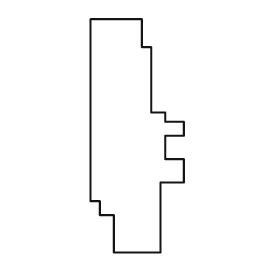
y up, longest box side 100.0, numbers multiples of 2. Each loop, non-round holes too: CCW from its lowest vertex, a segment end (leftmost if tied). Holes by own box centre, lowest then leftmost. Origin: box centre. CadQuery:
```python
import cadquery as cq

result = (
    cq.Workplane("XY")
    .moveTo(-10.0, -50.0)
    .lineTo(10.0, -50.0)
    .lineTo(10.0, -20.0)
    .lineTo(20.0, -20.0)
    .lineTo(20.0, -10.0)
    .lineTo(12.0, -10.0)
    .lineTo(12.0, 0.0)
    .lineTo(20.0, 0.0)
    .lineTo(20.0, 6.0)
    .lineTo(12.0, 6.0)
    .lineTo(12.0, 10.0)
    .lineTo(6.0, 10.0)
    .lineTo(6.0, 38.0)
    .lineTo(2.0, 38.0)
    .lineTo(2.0, 50.0)
    .lineTo(-20.0, 50.0)
    .lineTo(-20.0, -28.0)
    .lineTo(-16.0, -28.0)
    .lineTo(-16.0, -34.0)
    .lineTo(-10.0, -34.0)
    .close()
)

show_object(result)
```